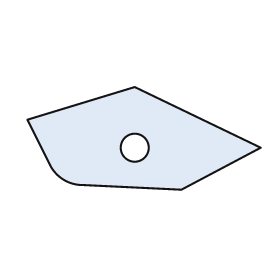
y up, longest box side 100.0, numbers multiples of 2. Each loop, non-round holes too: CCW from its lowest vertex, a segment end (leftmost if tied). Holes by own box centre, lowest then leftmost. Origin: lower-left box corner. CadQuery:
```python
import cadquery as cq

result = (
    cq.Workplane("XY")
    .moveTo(66.0, 0.0)
    .lineTo(100.0, 18.0)
    .lineTo(46.0, 44.0)
    .lineTo(0.0, 30.0)
    .lineTo(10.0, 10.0)
    .threePointArc((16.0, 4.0), (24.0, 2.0))
    .close()
    .moveTo(46.0, 18.0)
    .circle(6.0)
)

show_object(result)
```